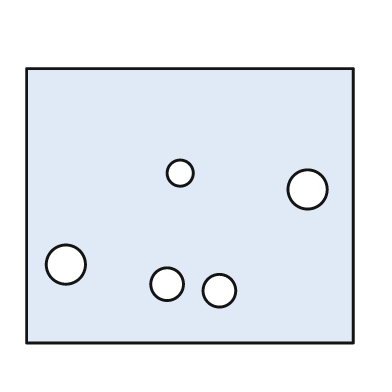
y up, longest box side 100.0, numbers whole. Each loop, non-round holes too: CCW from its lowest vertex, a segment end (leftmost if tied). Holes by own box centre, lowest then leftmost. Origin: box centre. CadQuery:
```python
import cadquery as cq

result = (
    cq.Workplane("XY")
    .moveTo(-50.0, -42.0)
    .lineTo(50.0, -42.0)
    .lineTo(50.0, 42.0)
    .lineTo(-50.0, 42.0)
    .close()
    .moveTo(9.0, -26.0)
    .circle(5.0)
    .moveTo(-7.0, -24.0)
    .circle(5.0)
    .moveTo(-38.0, -18.0)
    .circle(6.0)
    .moveTo(36.0, 5.0)
    .circle(6.0)
    .moveTo(-3.0, 10.0)
    .circle(4.0)
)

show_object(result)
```